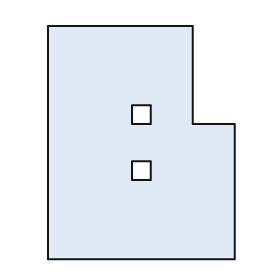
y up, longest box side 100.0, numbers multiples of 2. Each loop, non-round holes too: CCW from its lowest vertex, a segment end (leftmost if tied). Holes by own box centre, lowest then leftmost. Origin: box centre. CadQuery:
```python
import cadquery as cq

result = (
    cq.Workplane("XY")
    .moveTo(-40.0, -50.0)
    .lineTo(40.0, -50.0)
    .lineTo(40.0, 8.0)
    .lineTo(22.0, 8.0)
    .lineTo(22.0, 50.0)
    .lineTo(-40.0, 50.0)
    .close()
    .moveTo(-4.0, -16.0)
    .lineTo(4.0, -16.0)
    .lineTo(4.0, -8.0)
    .lineTo(-4.0, -8.0)
    .close()
    .moveTo(-4.0, 8.0)
    .lineTo(4.0, 8.0)
    .lineTo(4.0, 16.0)
    .lineTo(-4.0, 16.0)
    .close()
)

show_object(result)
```